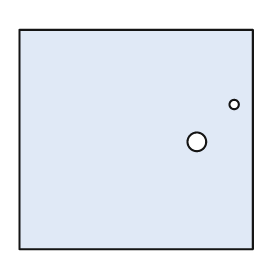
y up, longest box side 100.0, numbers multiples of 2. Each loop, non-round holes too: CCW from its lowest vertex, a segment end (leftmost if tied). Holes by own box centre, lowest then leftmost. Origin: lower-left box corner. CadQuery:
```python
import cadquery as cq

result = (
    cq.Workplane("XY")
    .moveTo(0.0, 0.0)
    .lineTo(100.0, 0.0)
    .lineTo(100.0, 94.0)
    .lineTo(0.0, 94.0)
    .close()
    .moveTo(76.0, 46.0)
    .circle(4.0)
    .moveTo(92.0, 62.0)
    .circle(2.0)
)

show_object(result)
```